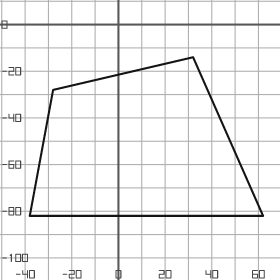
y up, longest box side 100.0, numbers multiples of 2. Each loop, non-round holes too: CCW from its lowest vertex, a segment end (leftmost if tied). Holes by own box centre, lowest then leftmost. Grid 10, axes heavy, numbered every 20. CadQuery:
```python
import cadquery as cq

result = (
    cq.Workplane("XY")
    .moveTo(-38.0, -82.0)
    .lineTo(62.0, -82.0)
    .lineTo(32.0, -14.0)
    .lineTo(-28.0, -28.0)
    .close()
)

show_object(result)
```